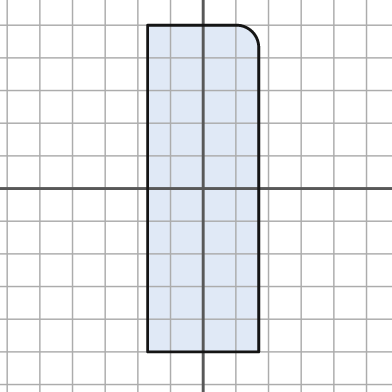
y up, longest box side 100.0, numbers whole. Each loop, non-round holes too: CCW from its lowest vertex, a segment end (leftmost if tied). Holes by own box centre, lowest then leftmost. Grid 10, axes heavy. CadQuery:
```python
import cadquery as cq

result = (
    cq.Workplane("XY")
    .moveTo(-17.0, -50.0)
    .lineTo(17.0, -50.0)
    .lineTo(17.0, 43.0)
    .threePointArc((15.0, 48.0), (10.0, 50.0))
    .lineTo(-17.0, 50.0)
    .close()
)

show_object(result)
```